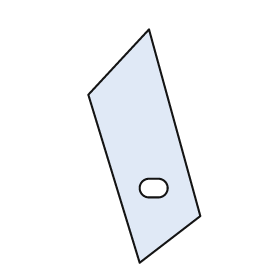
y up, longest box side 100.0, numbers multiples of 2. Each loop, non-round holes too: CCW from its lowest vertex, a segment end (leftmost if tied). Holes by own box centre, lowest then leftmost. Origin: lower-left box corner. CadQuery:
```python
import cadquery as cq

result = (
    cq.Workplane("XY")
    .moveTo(22.0, 0.0)
    .lineTo(48.0, 20.0)
    .lineTo(26.0, 100.0)
    .lineTo(0.0, 72.0)
    .close()
    .moveTo(26.0, 28.0)
    .lineTo(30.0, 28.0)
    .threePointArc((34.0, 32.0), (30.0, 36.0))
    .lineTo(26.0, 36.0)
    .threePointArc((22.0, 32.0), (26.0, 28.0))
    .close()
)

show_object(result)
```